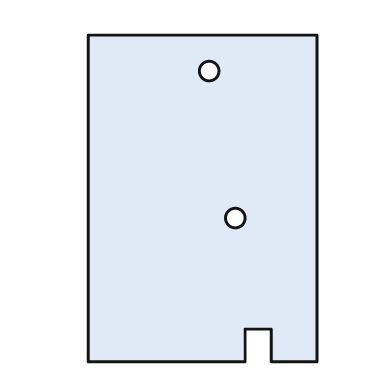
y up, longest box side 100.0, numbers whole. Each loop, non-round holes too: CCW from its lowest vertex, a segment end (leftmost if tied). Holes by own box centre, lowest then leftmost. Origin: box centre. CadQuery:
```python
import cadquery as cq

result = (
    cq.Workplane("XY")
    .moveTo(-35.0, -50.0)
    .lineTo(13.0, -50.0)
    .lineTo(13.0, -40.0)
    .lineTo(21.0, -40.0)
    .lineTo(21.0, -50.0)
    .lineTo(35.0, -50.0)
    .lineTo(35.0, 50.0)
    .lineTo(-35.0, 50.0)
    .close()
    .moveTo(10.0, -6.0)
    .circle(3.0)
    .moveTo(2.0, 39.0)
    .circle(3.0)
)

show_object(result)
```